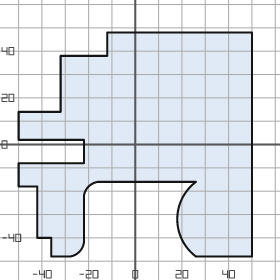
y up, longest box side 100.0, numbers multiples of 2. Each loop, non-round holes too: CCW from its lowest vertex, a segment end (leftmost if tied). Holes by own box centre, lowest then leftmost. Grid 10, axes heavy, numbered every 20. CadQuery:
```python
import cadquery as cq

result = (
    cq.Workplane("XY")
    .moveTo(-36.0, -48.0)
    .lineTo(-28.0, -48.0)
    .threePointArc((-24.0, -46.0), (-22.0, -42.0))
    .lineTo(-22.0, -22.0)
    .threePointArc((-20.0, -18.0), (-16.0, -16.0))
    .lineTo(26.0, -16.0)
    .threePointArc((18.0, -32.0), (26.0, -48.0))
    .lineTo(50.0, -48.0)
    .lineTo(50.0, 48.0)
    .lineTo(-12.0, 48.0)
    .lineTo(-12.0, 38.0)
    .lineTo(-32.0, 38.0)
    .lineTo(-32.0, 14.0)
    .lineTo(-50.0, 14.0)
    .lineTo(-50.0, 2.0)
    .lineTo(-22.0, 2.0)
    .lineTo(-22.0, -8.0)
    .lineTo(-50.0, -8.0)
    .lineTo(-50.0, -18.0)
    .lineTo(-42.0, -18.0)
    .lineTo(-42.0, -40.0)
    .lineTo(-36.0, -40.0)
    .close()
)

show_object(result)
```